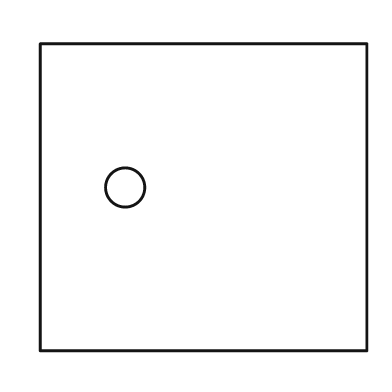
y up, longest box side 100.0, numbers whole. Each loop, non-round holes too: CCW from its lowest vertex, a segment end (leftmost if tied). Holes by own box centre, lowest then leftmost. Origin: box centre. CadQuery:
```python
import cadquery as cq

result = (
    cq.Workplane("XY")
    .moveTo(-50.0, -47.0)
    .lineTo(50.0, -47.0)
    .lineTo(50.0, 47.0)
    .lineTo(-50.0, 47.0)
    .close()
    .moveTo(-24.0, 3.0)
    .circle(6.0)
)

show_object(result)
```